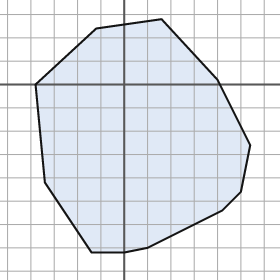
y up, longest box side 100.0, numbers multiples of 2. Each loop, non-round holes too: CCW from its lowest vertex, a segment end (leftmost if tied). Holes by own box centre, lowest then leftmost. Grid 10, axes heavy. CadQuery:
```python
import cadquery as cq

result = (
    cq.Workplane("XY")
    .moveTo(-14.0, -72.0)
    .lineTo(0.0, -72.0)
    .lineTo(10.0, -70.0)
    .lineTo(42.0, -54.0)
    .lineTo(50.0, -46.0)
    .lineTo(54.0, -26.0)
    .lineTo(40.0, 2.0)
    .lineTo(16.0, 28.0)
    .lineTo(-12.0, 24.0)
    .lineTo(-38.0, 0.0)
    .lineTo(-34.0, -42.0)
    .close()
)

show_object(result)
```